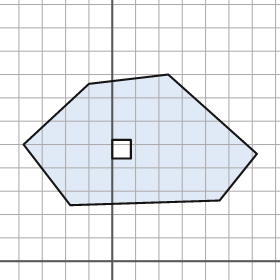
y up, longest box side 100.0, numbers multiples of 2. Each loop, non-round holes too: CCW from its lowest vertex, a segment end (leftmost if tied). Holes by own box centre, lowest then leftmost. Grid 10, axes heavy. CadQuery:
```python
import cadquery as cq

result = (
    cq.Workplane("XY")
    .moveTo(-18.0, 24.0)
    .lineTo(46.0, 26.0)
    .lineTo(62.0, 46.0)
    .lineTo(24.0, 80.0)
    .lineTo(-10.0, 76.0)
    .lineTo(-38.0, 50.0)
    .close()
    .moveTo(0.0, 44.0)
    .lineTo(8.0, 44.0)
    .lineTo(8.0, 52.0)
    .lineTo(0.0, 52.0)
    .close()
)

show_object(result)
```